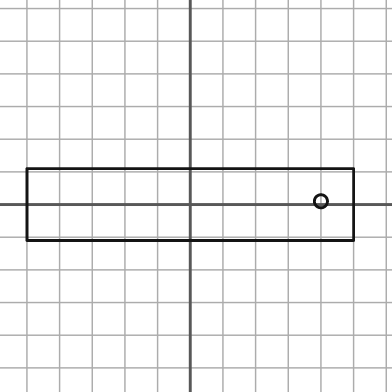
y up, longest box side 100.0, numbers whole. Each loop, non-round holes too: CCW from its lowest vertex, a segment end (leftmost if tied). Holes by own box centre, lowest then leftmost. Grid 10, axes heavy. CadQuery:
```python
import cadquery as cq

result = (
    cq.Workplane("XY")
    .moveTo(-50.0, -11.0)
    .lineTo(50.0, -11.0)
    .lineTo(50.0, 11.0)
    .lineTo(-50.0, 11.0)
    .close()
    .moveTo(40.0, 1.0)
    .circle(2.0)
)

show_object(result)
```